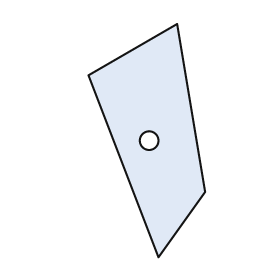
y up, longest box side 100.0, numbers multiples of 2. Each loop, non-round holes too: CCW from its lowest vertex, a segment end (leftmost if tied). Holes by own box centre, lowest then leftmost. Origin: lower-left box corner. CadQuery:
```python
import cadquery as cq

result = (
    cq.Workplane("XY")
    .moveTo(30.0, 0.0)
    .lineTo(50.0, 28.0)
    .lineTo(38.0, 100.0)
    .lineTo(0.0, 78.0)
    .close()
    .moveTo(26.0, 50.0)
    .circle(4.0)
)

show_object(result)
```